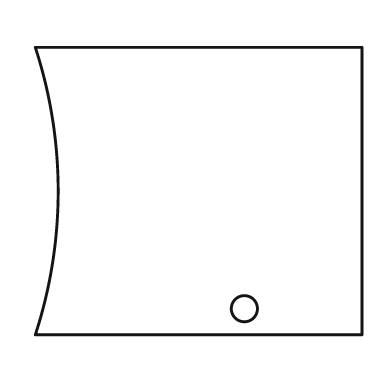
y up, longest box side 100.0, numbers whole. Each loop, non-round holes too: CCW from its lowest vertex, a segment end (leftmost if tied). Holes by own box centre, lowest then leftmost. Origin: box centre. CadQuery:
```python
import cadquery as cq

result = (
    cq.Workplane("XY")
    .moveTo(-50.0, -44.0)
    .lineTo(50.0, -44.0)
    .lineTo(50.0, 44.0)
    .lineTo(-50.0, 44.0)
    .threePointArc((-43.0, 0.0), (-50.0, -44.0))
    .close()
    .moveTo(14.0, -36.0)
    .circle(4.0)
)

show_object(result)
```